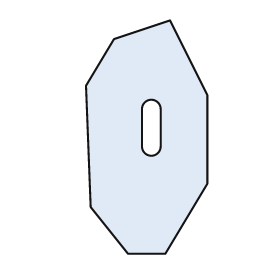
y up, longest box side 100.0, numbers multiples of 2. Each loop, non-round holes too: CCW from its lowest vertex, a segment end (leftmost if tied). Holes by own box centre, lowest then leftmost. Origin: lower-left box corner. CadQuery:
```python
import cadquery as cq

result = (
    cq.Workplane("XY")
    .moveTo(18.0, 0.0)
    .lineTo(34.0, 0.0)
    .lineTo(52.0, 30.0)
    .lineTo(52.0, 68.0)
    .lineTo(36.0, 100.0)
    .lineTo(12.0, 92.0)
    .lineTo(0.0, 72.0)
    .lineTo(2.0, 20.0)
    .close()
    .moveTo(24.0, 46.0)
    .threePointArc((28.0, 42.0), (32.0, 46.0))
    .lineTo(32.0, 62.0)
    .threePointArc((28.0, 66.0), (24.0, 62.0))
    .close()
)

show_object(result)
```